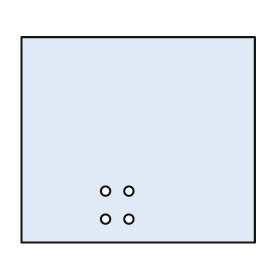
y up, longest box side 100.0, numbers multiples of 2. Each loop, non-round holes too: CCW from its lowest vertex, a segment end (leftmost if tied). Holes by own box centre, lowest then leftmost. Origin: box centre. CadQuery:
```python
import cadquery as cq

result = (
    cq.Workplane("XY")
    .moveTo(-50.0, -44.0)
    .lineTo(50.0, -44.0)
    .lineTo(50.0, 44.0)
    .lineTo(-50.0, 44.0)
    .close()
    .moveTo(-14.0, -34.0)
    .circle(2.0)
    .moveTo(-4.0, -34.0)
    .circle(2.0)
    .moveTo(-14.0, -22.0)
    .circle(2.0)
    .moveTo(-4.0, -22.0)
    .circle(2.0)
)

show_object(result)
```